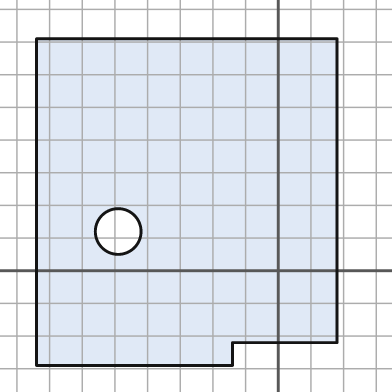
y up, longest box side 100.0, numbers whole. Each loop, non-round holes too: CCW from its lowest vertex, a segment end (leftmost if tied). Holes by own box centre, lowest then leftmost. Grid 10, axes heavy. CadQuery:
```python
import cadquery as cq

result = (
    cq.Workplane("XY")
    .moveTo(-74.0, -29.0)
    .lineTo(-14.0, -29.0)
    .lineTo(-14.0, -22.0)
    .lineTo(18.0, -22.0)
    .lineTo(18.0, 71.0)
    .lineTo(-74.0, 71.0)
    .close()
    .moveTo(-49.0, 12.0)
    .circle(7.0)
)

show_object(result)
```